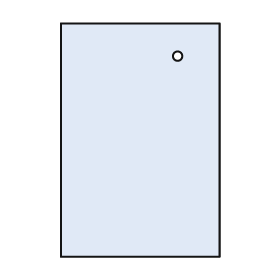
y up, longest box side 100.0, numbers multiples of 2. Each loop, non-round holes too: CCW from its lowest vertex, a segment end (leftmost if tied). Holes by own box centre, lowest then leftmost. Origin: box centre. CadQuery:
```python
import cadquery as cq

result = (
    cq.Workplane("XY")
    .moveTo(-34.0, -50.0)
    .lineTo(34.0, -50.0)
    .lineTo(34.0, 50.0)
    .lineTo(-34.0, 50.0)
    .close()
    .moveTo(16.0, 36.0)
    .circle(2.0)
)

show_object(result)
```